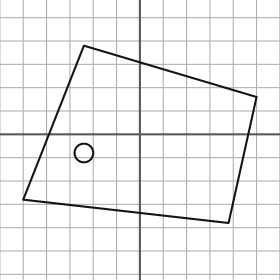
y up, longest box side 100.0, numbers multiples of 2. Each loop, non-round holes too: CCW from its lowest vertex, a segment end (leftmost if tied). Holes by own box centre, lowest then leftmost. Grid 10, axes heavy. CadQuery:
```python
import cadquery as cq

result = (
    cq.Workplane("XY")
    .moveTo(38.0, -38.0)
    .lineTo(50.0, 16.0)
    .lineTo(-24.0, 38.0)
    .lineTo(-50.0, -28.0)
    .close()
    .moveTo(-24.0, -8.0)
    .circle(4.0)
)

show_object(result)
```